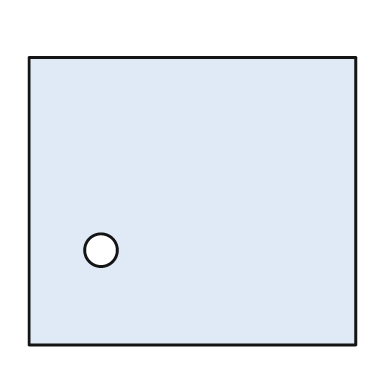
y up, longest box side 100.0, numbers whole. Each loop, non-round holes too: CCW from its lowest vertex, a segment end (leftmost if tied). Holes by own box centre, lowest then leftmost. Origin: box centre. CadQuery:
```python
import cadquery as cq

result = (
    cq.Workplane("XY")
    .moveTo(-50.0, -44.0)
    .lineTo(50.0, -44.0)
    .lineTo(50.0, 44.0)
    .lineTo(-50.0, 44.0)
    .close()
    .moveTo(-28.0, -15.0)
    .circle(5.0)
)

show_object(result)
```